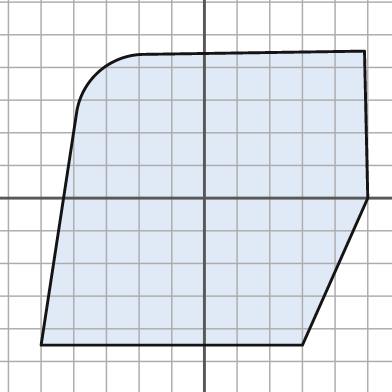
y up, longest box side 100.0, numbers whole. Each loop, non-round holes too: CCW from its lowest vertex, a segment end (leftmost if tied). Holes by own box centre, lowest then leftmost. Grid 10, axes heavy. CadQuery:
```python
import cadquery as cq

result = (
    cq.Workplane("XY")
    .moveTo(-50.0, -45.0)
    .lineTo(30.0, -45.0)
    .lineTo(50.0, 0.0)
    .lineTo(49.0, 45.0)
    .lineTo(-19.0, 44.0)
    .threePointArc((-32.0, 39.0), (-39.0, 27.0))
    .close()
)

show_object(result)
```